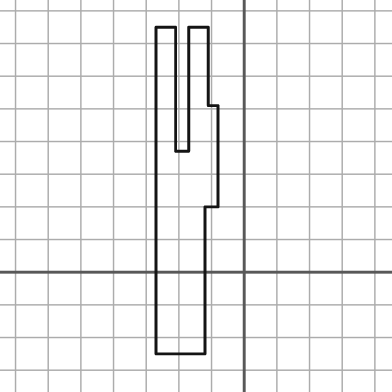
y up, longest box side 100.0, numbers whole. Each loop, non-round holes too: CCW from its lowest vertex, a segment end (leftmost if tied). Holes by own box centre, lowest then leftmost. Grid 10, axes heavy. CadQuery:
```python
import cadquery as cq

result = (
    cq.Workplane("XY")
    .moveTo(-27.0, -25.0)
    .lineTo(-12.0, -25.0)
    .lineTo(-12.0, 20.0)
    .lineTo(-8.0, 20.0)
    .lineTo(-8.0, 51.0)
    .lineTo(-11.0, 51.0)
    .lineTo(-11.0, 75.0)
    .lineTo(-17.0, 75.0)
    .lineTo(-17.0, 37.0)
    .lineTo(-21.0, 37.0)
    .lineTo(-21.0, 75.0)
    .lineTo(-27.0, 75.0)
    .close()
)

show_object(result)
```